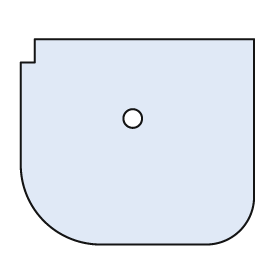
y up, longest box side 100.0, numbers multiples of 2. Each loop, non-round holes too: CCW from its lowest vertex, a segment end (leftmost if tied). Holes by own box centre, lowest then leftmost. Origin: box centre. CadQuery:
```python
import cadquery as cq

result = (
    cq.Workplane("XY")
    .moveTo(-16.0, -44.0)
    .lineTo(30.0, -44.0)
    .threePointArc((44.0, -38.0), (50.0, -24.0))
    .lineTo(50.0, 44.0)
    .lineTo(-44.0, 44.0)
    .lineTo(-44.0, 34.0)
    .lineTo(-50.0, 34.0)
    .lineTo(-50.0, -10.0)
    .threePointArc((-40.0, -34.0), (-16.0, -44.0))
    .close()
    .moveTo(-2.0, 10.0)
    .circle(4.0)
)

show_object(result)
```